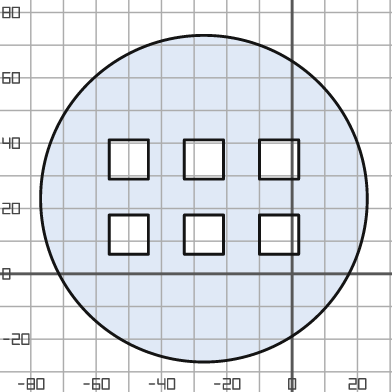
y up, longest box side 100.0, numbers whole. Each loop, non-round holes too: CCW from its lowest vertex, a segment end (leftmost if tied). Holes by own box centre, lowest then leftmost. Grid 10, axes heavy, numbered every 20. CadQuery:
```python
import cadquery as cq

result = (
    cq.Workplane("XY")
    .moveTo(-27.0, 23.0)
    .circle(50.0)
    .moveTo(-56.0, 6.0)
    .lineTo(-44.0, 6.0)
    .lineTo(-44.0, 18.0)
    .lineTo(-56.0, 18.0)
    .close()
    .moveTo(-33.0, 6.0)
    .lineTo(-21.0, 6.0)
    .lineTo(-21.0, 18.0)
    .lineTo(-33.0, 18.0)
    .close()
    .moveTo(-10.0, 6.0)
    .lineTo(2.0, 6.0)
    .lineTo(2.0, 18.0)
    .lineTo(-10.0, 18.0)
    .close()
    .moveTo(-56.0, 29.0)
    .lineTo(-44.0, 29.0)
    .lineTo(-44.0, 41.0)
    .lineTo(-56.0, 41.0)
    .close()
    .moveTo(-33.0, 29.0)
    .lineTo(-21.0, 29.0)
    .lineTo(-21.0, 41.0)
    .lineTo(-33.0, 41.0)
    .close()
    .moveTo(-10.0, 29.0)
    .lineTo(2.0, 29.0)
    .lineTo(2.0, 41.0)
    .lineTo(-10.0, 41.0)
    .close()
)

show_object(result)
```